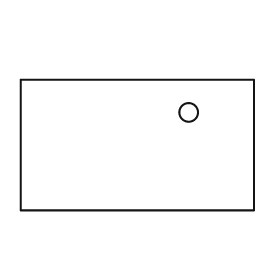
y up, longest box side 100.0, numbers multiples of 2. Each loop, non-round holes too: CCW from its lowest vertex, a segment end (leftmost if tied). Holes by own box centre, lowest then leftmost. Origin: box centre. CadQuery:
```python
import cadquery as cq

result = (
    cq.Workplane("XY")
    .moveTo(-50.0, -28.0)
    .lineTo(50.0, -28.0)
    .lineTo(50.0, 28.0)
    .lineTo(-50.0, 28.0)
    .close()
    .moveTo(22.0, 14.0)
    .circle(4.0)
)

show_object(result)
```